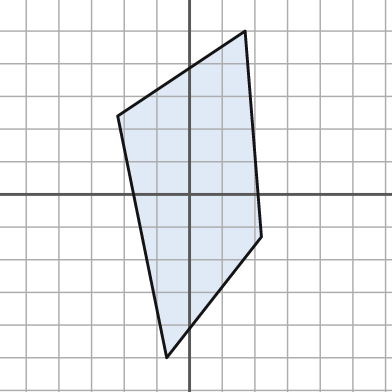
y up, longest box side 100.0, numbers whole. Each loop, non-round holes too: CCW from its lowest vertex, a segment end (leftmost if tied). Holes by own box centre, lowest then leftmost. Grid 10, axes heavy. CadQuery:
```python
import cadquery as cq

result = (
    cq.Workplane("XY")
    .moveTo(-7.0, -50.0)
    .lineTo(22.0, -13.0)
    .lineTo(17.0, 50.0)
    .lineTo(-22.0, 24.0)
    .close()
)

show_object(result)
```